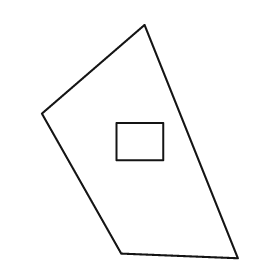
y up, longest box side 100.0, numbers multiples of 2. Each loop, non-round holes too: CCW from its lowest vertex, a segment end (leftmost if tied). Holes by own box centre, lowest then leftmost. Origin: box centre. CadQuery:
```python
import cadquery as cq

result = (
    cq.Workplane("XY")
    .moveTo(42.0, -50.0)
    .lineTo(2.0, 50.0)
    .lineTo(-42.0, 12.0)
    .lineTo(-8.0, -48.0)
    .close()
    .moveTo(-10.0, -8.0)
    .lineTo(10.0, -8.0)
    .lineTo(10.0, 8.0)
    .lineTo(-10.0, 8.0)
    .close()
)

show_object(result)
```